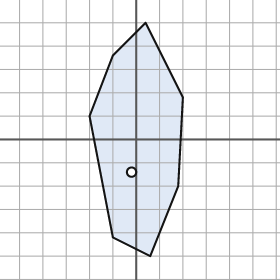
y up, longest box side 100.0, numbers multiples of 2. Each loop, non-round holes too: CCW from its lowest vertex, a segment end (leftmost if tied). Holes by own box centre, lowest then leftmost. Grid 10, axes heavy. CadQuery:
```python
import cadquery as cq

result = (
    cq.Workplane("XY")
    .moveTo(6.0, -50.0)
    .lineTo(18.0, -20.0)
    .lineTo(20.0, 18.0)
    .lineTo(4.0, 50.0)
    .lineTo(-10.0, 36.0)
    .lineTo(-20.0, 10.0)
    .lineTo(-10.0, -42.0)
    .close()
    .moveTo(-2.0, -14.0)
    .circle(2.0)
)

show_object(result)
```